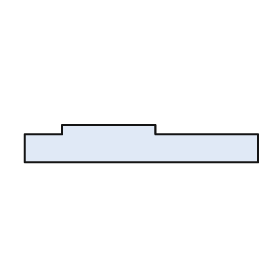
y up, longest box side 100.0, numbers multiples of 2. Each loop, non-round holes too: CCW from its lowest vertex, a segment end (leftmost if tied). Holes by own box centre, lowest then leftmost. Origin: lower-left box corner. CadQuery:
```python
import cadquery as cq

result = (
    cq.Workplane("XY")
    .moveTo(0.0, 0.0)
    .lineTo(100.0, 0.0)
    .lineTo(100.0, 12.0)
    .lineTo(56.0, 12.0)
    .lineTo(56.0, 16.0)
    .lineTo(16.0, 16.0)
    .lineTo(16.0, 12.0)
    .lineTo(0.0, 12.0)
    .close()
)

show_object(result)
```